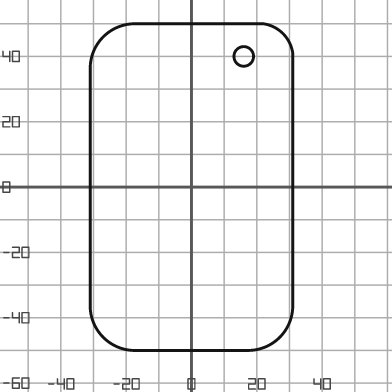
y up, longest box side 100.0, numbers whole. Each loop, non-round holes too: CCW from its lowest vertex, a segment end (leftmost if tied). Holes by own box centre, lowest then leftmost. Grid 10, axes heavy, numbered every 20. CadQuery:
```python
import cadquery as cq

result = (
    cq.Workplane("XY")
    .moveTo(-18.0, -50.0)
    .lineTo(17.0, -50.0)
    .threePointArc((27.0, -46.0), (31.0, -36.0))
    .lineTo(31.0, 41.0)
    .threePointArc((28.0, 47.0), (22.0, 50.0))
    .lineTo(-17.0, 50.0)
    .threePointArc((-27.0, 46.0), (-31.0, 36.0))
    .lineTo(-31.0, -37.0)
    .threePointArc((-27.0, -46.0), (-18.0, -50.0))
    .close()
    .moveTo(16.0, 40.0)
    .circle(3.0)
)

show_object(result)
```